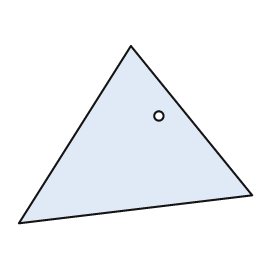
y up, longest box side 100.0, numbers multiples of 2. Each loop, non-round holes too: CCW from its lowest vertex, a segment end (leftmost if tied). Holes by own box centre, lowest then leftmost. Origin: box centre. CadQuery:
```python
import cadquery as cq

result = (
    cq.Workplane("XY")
    .moveTo(-50.0, -38.0)
    .lineTo(50.0, -26.0)
    .lineTo(-2.0, 38.0)
    .close()
    .moveTo(10.0, 8.0)
    .circle(2.0)
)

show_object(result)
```